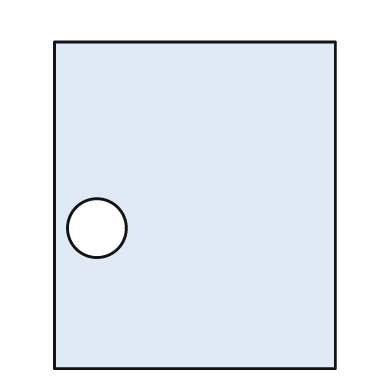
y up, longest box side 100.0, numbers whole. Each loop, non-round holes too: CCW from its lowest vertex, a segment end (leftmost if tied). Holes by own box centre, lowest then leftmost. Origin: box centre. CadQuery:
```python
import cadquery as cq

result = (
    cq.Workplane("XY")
    .moveTo(-43.0, -50.0)
    .lineTo(43.0, -50.0)
    .lineTo(43.0, 50.0)
    .lineTo(-43.0, 50.0)
    .close()
    .moveTo(-30.0, -7.0)
    .circle(9.0)
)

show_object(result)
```